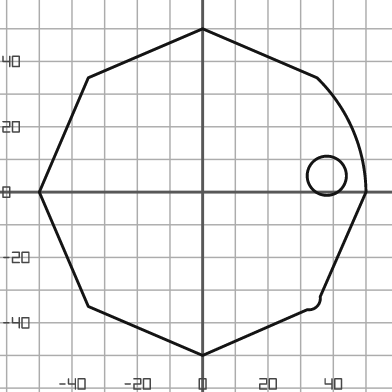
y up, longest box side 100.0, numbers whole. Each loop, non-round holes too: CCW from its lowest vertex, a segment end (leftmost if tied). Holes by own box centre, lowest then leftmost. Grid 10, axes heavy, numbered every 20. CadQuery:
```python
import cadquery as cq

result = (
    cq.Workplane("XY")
    .moveTo(0.0, -50.0)
    .lineTo(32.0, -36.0)
    .threePointArc((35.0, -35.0), (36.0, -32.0))
    .lineTo(50.0, 0.0)
    .threePointArc((46.0, 19.0), (35.0, 35.0))
    .lineTo(0.0, 50.0)
    .lineTo(-35.0, 35.0)
    .lineTo(-50.0, 0.0)
    .lineTo(-35.0, -35.0)
    .close()
    .moveTo(38.0, 5.0)
    .circle(6.0)
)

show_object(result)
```